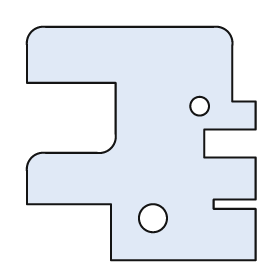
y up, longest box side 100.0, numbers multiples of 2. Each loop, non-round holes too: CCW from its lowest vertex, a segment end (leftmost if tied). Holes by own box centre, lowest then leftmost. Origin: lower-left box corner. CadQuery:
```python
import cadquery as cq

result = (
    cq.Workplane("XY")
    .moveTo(36.0, 0.0)
    .lineTo(98.0, 0.0)
    .lineTo(98.0, 22.0)
    .lineTo(80.0, 22.0)
    .lineTo(80.0, 26.0)
    .lineTo(98.0, 26.0)
    .lineTo(98.0, 44.0)
    .lineTo(76.0, 44.0)
    .lineTo(76.0, 56.0)
    .lineTo(98.0, 56.0)
    .lineTo(98.0, 68.0)
    .lineTo(88.0, 68.0)
    .lineTo(88.0, 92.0)
    .threePointArc((86.0, 98.0), (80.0, 100.0))
    .lineTo(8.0, 100.0)
    .threePointArc((2.0, 98.0), (0.0, 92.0))
    .lineTo(0.0, 76.0)
    .lineTo(38.0, 76.0)
    .lineTo(38.0, 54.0)
    .threePointArc((36.0, 48.0), (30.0, 46.0))
    .lineTo(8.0, 46.0)
    .threePointArc((2.0, 44.0), (0.0, 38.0))
    .lineTo(0.0, 24.0)
    .lineTo(36.0, 24.0)
    .close()
    .moveTo(54.0, 18.0)
    .circle(6.0)
    .moveTo(74.0, 66.0)
    .circle(4.0)
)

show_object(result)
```